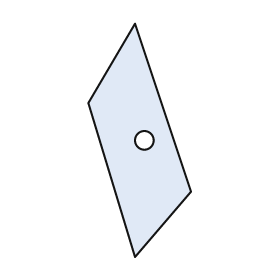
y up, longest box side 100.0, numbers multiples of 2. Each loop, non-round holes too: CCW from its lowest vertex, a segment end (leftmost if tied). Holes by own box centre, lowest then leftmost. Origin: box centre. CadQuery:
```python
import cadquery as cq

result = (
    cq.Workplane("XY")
    .moveTo(-2.0, -50.0)
    .lineTo(22.0, -22.0)
    .lineTo(-2.0, 50.0)
    .lineTo(-22.0, 16.0)
    .close()
    .moveTo(2.0, 0.0)
    .circle(4.0)
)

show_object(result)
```